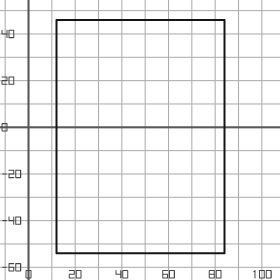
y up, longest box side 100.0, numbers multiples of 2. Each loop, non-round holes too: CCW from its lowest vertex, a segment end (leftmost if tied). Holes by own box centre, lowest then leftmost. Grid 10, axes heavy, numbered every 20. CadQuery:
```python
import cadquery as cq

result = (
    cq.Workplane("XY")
    .moveTo(12.0, -54.0)
    .lineTo(84.0, -54.0)
    .lineTo(84.0, 46.0)
    .lineTo(12.0, 46.0)
    .close()
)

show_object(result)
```